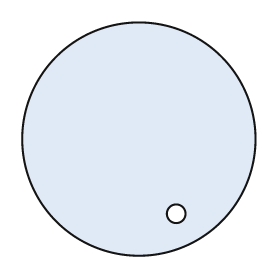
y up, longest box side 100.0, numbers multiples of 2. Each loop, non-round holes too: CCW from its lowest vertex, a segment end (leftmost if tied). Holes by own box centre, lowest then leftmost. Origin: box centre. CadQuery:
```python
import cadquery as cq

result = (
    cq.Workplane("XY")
    .moveTo(0.0, 0.0)
    .circle(50.0)
    .moveTo(16.0, -32.0)
    .circle(4.0)
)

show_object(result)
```